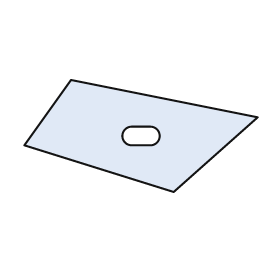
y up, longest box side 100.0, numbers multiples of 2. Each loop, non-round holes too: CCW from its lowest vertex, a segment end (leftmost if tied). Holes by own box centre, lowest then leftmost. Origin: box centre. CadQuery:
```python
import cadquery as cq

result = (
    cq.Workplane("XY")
    .moveTo(14.0, -24.0)
    .lineTo(50.0, 8.0)
    .lineTo(-30.0, 24.0)
    .lineTo(-50.0, -4.0)
    .close()
    .moveTo(-4.0, -4.0)
    .lineTo(4.0, -4.0)
    .threePointArc((8.0, 0.0), (4.0, 4.0))
    .lineTo(-4.0, 4.0)
    .threePointArc((-8.0, 0.0), (-4.0, -4.0))
    .close()
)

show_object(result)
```